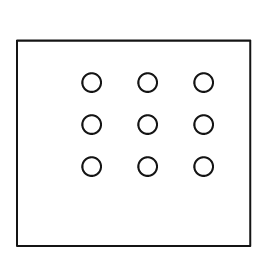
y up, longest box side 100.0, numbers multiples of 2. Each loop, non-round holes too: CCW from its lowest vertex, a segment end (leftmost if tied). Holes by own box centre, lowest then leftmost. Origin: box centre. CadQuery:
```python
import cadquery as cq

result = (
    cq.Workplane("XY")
    .moveTo(-50.0, -44.0)
    .lineTo(50.0, -44.0)
    .lineTo(50.0, 44.0)
    .lineTo(-50.0, 44.0)
    .close()
    .moveTo(-18.0, -10.0)
    .circle(4.0)
    .moveTo(6.0, -10.0)
    .circle(4.0)
    .moveTo(30.0, -10.0)
    .circle(4.0)
    .moveTo(-18.0, 8.0)
    .circle(4.0)
    .moveTo(6.0, 8.0)
    .circle(4.0)
    .moveTo(30.0, 8.0)
    .circle(4.0)
    .moveTo(-18.0, 26.0)
    .circle(4.0)
    .moveTo(6.0, 26.0)
    .circle(4.0)
    .moveTo(30.0, 26.0)
    .circle(4.0)
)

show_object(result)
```